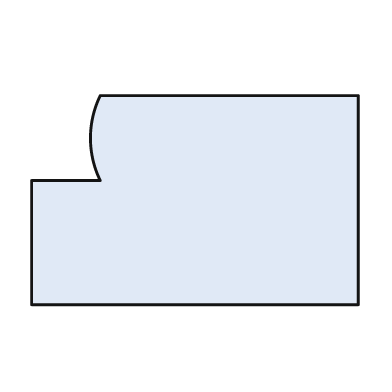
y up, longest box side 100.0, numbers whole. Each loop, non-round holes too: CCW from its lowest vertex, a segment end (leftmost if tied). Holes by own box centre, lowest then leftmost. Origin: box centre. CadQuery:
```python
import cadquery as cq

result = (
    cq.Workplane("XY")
    .moveTo(-50.0, -32.0)
    .lineTo(50.0, -32.0)
    .lineTo(50.0, 32.0)
    .lineTo(-29.0, 32.0)
    .threePointArc((-32.0, 19.0), (-29.0, 6.0))
    .lineTo(-50.0, 6.0)
    .close()
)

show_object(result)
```